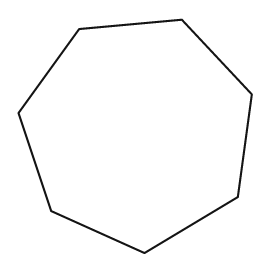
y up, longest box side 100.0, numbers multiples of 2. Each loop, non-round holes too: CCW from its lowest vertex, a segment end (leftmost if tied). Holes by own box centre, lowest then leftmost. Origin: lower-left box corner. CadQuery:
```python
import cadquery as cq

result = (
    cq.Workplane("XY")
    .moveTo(54.0, 0.0)
    .lineTo(94.0, 24.0)
    .lineTo(100.0, 68.0)
    .lineTo(70.0, 100.0)
    .lineTo(26.0, 96.0)
    .lineTo(0.0, 60.0)
    .lineTo(14.0, 18.0)
    .close()
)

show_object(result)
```